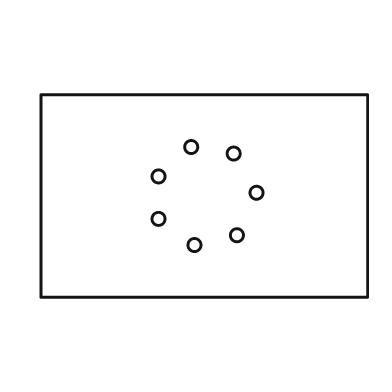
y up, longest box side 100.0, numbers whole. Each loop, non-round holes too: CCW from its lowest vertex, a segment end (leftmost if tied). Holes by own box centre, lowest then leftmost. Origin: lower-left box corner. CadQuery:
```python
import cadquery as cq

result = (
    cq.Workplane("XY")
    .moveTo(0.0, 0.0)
    .lineTo(100.0, 0.0)
    .lineTo(100.0, 62.0)
    .lineTo(0.0, 62.0)
    .close()
    .moveTo(47.0, 16.0)
    .circle(2.0)
    .moveTo(60.0, 19.0)
    .circle(2.0)
    .moveTo(36.0, 24.0)
    .circle(2.0)
    .moveTo(66.0, 32.0)
    .circle(2.0)
    .moveTo(36.0, 37.0)
    .circle(2.0)
    .moveTo(59.0, 44.0)
    .circle(2.0)
    .moveTo(46.0, 46.0)
    .circle(2.0)
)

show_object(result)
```